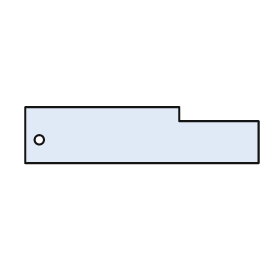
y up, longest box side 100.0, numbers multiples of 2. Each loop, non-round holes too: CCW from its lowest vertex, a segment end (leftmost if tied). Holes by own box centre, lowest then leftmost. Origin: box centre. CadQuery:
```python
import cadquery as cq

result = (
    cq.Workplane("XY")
    .moveTo(-50.0, -12.0)
    .lineTo(50.0, -12.0)
    .lineTo(50.0, 6.0)
    .lineTo(16.0, 6.0)
    .lineTo(16.0, 12.0)
    .lineTo(-50.0, 12.0)
    .close()
    .moveTo(-44.0, -2.0)
    .circle(2.0)
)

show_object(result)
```